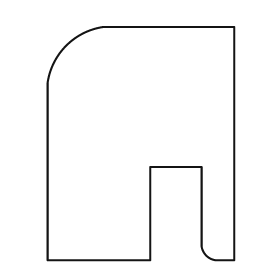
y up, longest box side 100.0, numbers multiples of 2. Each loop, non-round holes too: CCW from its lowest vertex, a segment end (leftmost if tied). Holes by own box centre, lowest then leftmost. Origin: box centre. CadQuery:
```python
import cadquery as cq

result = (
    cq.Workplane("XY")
    .moveTo(-40.0, -50.0)
    .lineTo(4.0, -50.0)
    .lineTo(4.0, -10.0)
    .lineTo(26.0, -10.0)
    .lineTo(26.0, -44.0)
    .threePointArc((28.0, -48.0), (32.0, -50.0))
    .lineTo(40.0, -50.0)
    .lineTo(40.0, 50.0)
    .lineTo(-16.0, 50.0)
    .threePointArc((-32.0, 42.0), (-40.0, 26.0))
    .close()
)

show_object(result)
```